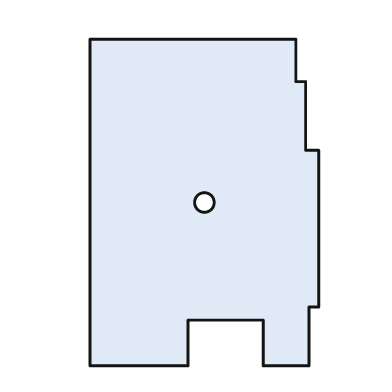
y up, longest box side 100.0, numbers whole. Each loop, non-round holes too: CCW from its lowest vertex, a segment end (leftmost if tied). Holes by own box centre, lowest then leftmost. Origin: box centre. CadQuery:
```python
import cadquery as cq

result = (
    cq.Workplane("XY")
    .moveTo(-35.0, -50.0)
    .lineTo(-5.0, -50.0)
    .lineTo(-5.0, -36.0)
    .lineTo(18.0, -36.0)
    .lineTo(18.0, -50.0)
    .lineTo(32.0, -50.0)
    .lineTo(32.0, -32.0)
    .lineTo(35.0, -32.0)
    .lineTo(35.0, 16.0)
    .lineTo(31.0, 16.0)
    .lineTo(31.0, 37.0)
    .lineTo(28.0, 37.0)
    .lineTo(28.0, 50.0)
    .lineTo(-35.0, 50.0)
    .close()
    .moveTo(0.0, 0.0)
    .circle(3.0)
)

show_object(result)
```